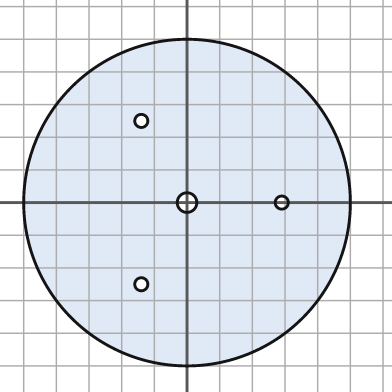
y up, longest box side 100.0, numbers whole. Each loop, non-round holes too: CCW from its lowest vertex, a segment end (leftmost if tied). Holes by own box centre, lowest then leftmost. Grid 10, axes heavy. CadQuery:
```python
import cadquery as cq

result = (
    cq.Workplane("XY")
    .moveTo(0.0, 0.0)
    .circle(50.0)
    .moveTo(-14.0, -25.0)
    .circle(2.0)
    .moveTo(0.0, 0.0)
    .circle(3.0)
    .moveTo(29.0, 0.0)
    .circle(2.0)
    .moveTo(-14.0, 25.0)
    .circle(2.0)
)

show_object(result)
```